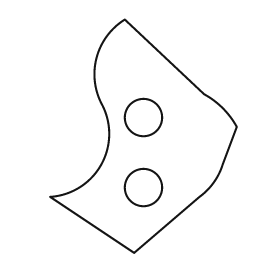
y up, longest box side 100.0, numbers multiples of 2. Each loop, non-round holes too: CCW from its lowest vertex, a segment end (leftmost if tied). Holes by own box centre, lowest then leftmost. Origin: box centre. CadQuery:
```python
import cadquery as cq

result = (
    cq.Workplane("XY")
    .moveTo(-4.0, -50.0)
    .lineTo(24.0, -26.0)
    .threePointArc((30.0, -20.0), (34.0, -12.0))
    .lineTo(40.0, 4.0)
    .threePointArc((34.0, 12.0), (26.0, 18.0))
    .lineTo(-8.0, 50.0)
    .threePointArc((-20.0, 34.0), (-18.0, 14.0))
    .threePointArc((-18.0, -12.0), (-40.0, -26.0))
    .close()
    .moveTo(0.0, -22.0)
    .circle(8.0)
    .moveTo(0.0, 8.0)
    .circle(8.0)
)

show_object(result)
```